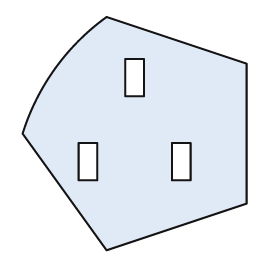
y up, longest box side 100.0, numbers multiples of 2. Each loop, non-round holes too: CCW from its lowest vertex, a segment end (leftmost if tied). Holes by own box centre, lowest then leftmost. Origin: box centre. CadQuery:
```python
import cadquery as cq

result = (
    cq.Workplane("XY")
    .moveTo(-12.0, -50.0)
    .lineTo(48.0, -30.0)
    .lineTo(48.0, 30.0)
    .lineTo(-12.0, 50.0)
    .threePointArc((-34.0, 28.0), (-48.0, 0.0))
    .close()
    .moveTo(-24.0, -20.0)
    .lineTo(-16.0, -20.0)
    .lineTo(-16.0, -4.0)
    .lineTo(-24.0, -4.0)
    .close()
    .moveTo(16.0, -20.0)
    .lineTo(24.0, -20.0)
    .lineTo(24.0, -4.0)
    .lineTo(16.0, -4.0)
    .close()
    .moveTo(-4.0, 16.0)
    .lineTo(4.0, 16.0)
    .lineTo(4.0, 32.0)
    .lineTo(-4.0, 32.0)
    .close()
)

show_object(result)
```